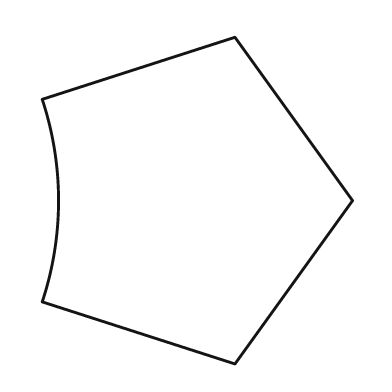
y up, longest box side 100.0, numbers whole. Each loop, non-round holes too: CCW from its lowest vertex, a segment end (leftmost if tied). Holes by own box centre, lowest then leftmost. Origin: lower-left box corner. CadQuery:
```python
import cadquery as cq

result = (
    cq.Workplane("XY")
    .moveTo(59.0, 0.0)
    .lineTo(95.0, 50.0)
    .lineTo(59.0, 100.0)
    .lineTo(0.0, 81.0)
    .threePointArc((5.0, 50.0), (0.0, 19.0))
    .close()
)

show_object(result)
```